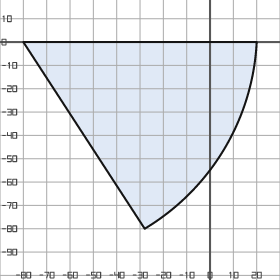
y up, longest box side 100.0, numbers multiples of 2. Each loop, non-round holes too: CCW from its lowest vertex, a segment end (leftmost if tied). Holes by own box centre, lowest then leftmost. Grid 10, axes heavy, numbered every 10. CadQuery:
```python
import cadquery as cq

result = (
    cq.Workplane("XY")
    .moveTo(-28.0, -80.0)
    .threePointArc((6.0, -46.0), (20.0, 0.0))
    .lineTo(-80.0, 0.0)
    .close()
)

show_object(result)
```